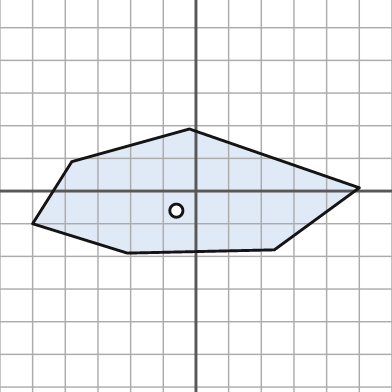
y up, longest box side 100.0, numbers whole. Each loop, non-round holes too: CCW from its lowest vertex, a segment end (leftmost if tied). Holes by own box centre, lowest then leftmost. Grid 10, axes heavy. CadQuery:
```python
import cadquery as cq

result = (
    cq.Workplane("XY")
    .moveTo(-21.0, -19.0)
    .lineTo(24.0, -18.0)
    .lineTo(50.0, 1.0)
    .lineTo(-2.0, 19.0)
    .lineTo(-38.0, 9.0)
    .lineTo(-50.0, -10.0)
    .close()
    .moveTo(-6.0, -6.0)
    .circle(2.0)
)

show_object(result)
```